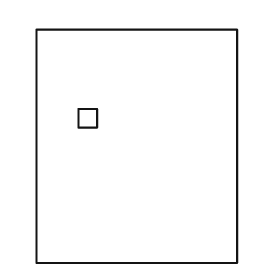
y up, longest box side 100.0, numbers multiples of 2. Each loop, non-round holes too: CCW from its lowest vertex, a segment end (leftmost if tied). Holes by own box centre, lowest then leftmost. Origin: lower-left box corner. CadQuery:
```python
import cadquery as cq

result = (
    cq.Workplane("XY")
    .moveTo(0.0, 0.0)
    .lineTo(86.0, 0.0)
    .lineTo(86.0, 100.0)
    .lineTo(0.0, 100.0)
    .close()
    .moveTo(18.0, 58.0)
    .lineTo(26.0, 58.0)
    .lineTo(26.0, 66.0)
    .lineTo(18.0, 66.0)
    .close()
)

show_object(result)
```